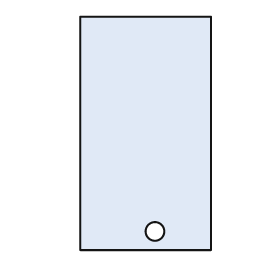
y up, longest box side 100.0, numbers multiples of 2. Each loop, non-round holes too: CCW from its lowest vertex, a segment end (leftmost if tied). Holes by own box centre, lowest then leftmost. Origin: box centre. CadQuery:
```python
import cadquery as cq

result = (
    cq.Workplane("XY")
    .moveTo(-28.0, -50.0)
    .lineTo(28.0, -50.0)
    .lineTo(28.0, 50.0)
    .lineTo(-28.0, 50.0)
    .close()
    .moveTo(4.0, -42.0)
    .circle(4.0)
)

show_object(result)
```